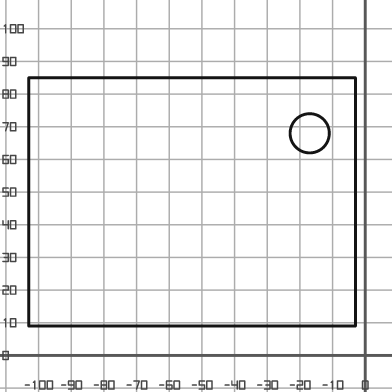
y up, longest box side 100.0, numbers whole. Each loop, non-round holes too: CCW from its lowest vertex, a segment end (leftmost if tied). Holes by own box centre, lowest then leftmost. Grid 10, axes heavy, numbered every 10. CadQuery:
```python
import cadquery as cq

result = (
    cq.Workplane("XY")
    .moveTo(-103.0, 9.0)
    .lineTo(-3.0, 9.0)
    .lineTo(-3.0, 85.0)
    .lineTo(-103.0, 85.0)
    .close()
    .moveTo(-17.0, 68.0)
    .circle(6.0)
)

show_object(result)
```